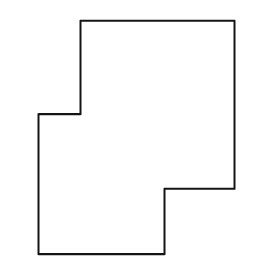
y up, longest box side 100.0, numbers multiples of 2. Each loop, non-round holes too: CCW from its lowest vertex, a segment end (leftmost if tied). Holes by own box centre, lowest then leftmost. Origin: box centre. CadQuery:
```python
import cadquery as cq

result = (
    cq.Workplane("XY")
    .moveTo(-42.0, -50.0)
    .lineTo(12.0, -50.0)
    .lineTo(12.0, -22.0)
    .lineTo(42.0, -22.0)
    .lineTo(42.0, 50.0)
    .lineTo(-24.0, 50.0)
    .lineTo(-24.0, 10.0)
    .lineTo(-42.0, 10.0)
    .close()
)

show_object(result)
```